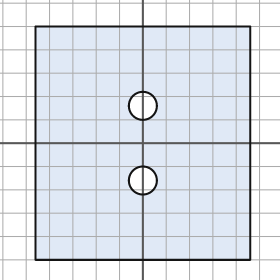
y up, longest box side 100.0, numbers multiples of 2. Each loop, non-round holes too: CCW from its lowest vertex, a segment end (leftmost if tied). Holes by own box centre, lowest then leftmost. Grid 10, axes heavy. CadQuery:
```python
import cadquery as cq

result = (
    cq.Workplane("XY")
    .moveTo(-46.0, -50.0)
    .lineTo(46.0, -50.0)
    .lineTo(46.0, 50.0)
    .lineTo(-46.0, 50.0)
    .close()
    .moveTo(0.0, -16.0)
    .circle(6.0)
    .moveTo(0.0, 16.0)
    .circle(6.0)
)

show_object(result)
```